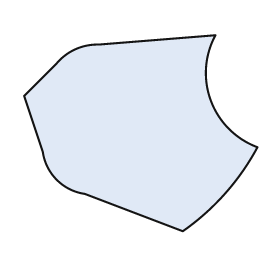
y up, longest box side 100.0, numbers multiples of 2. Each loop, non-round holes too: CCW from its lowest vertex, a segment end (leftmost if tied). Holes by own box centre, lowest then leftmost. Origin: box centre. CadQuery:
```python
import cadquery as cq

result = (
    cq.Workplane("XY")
    .moveTo(18.0, -42.0)
    .threePointArc((36.0, -26.0), (50.0, -6.0))
    .threePointArc((30.0, 14.0), (32.0, 42.0))
    .lineTo(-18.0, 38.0)
    .threePointArc((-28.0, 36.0), (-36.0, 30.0))
    .lineTo(-50.0, 16.0)
    .lineTo(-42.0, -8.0)
    .threePointArc((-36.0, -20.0), (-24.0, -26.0))
    .close()
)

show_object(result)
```